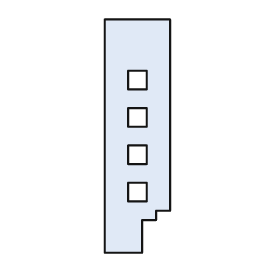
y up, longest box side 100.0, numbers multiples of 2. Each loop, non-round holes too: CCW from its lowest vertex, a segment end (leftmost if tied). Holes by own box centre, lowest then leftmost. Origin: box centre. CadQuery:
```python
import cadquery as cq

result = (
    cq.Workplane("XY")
    .moveTo(-14.0, -50.0)
    .lineTo(2.0, -50.0)
    .lineTo(2.0, -36.0)
    .lineTo(8.0, -36.0)
    .lineTo(8.0, -32.0)
    .lineTo(14.0, -32.0)
    .lineTo(14.0, 50.0)
    .lineTo(-14.0, 50.0)
    .close()
    .moveTo(-4.0, -28.0)
    .lineTo(4.0, -28.0)
    .lineTo(4.0, -20.0)
    .lineTo(-4.0, -20.0)
    .close()
    .moveTo(-4.0, -12.0)
    .lineTo(4.0, -12.0)
    .lineTo(4.0, -4.0)
    .lineTo(-4.0, -4.0)
    .close()
    .moveTo(-4.0, 4.0)
    .lineTo(4.0, 4.0)
    .lineTo(4.0, 12.0)
    .lineTo(-4.0, 12.0)
    .close()
    .moveTo(-4.0, 20.0)
    .lineTo(4.0, 20.0)
    .lineTo(4.0, 28.0)
    .lineTo(-4.0, 28.0)
    .close()
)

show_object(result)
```